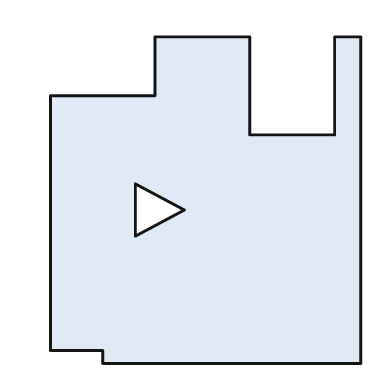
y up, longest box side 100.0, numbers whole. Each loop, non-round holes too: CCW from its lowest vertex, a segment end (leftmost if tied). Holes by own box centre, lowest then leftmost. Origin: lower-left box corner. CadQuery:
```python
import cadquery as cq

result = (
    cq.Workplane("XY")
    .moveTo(16.0, 0.0)
    .lineTo(95.0, 0.0)
    .lineTo(95.0, 100.0)
    .lineTo(87.0, 100.0)
    .lineTo(87.0, 70.0)
    .lineTo(61.0, 70.0)
    .lineTo(61.0, 100.0)
    .lineTo(32.0, 100.0)
    .lineTo(32.0, 82.0)
    .lineTo(0.0, 82.0)
    .lineTo(0.0, 4.0)
    .lineTo(16.0, 4.0)
    .close()
    .moveTo(26.0, 39.0)
    .lineTo(41.0, 47.0)
    .lineTo(26.0, 55.0)
    .close()
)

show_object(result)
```